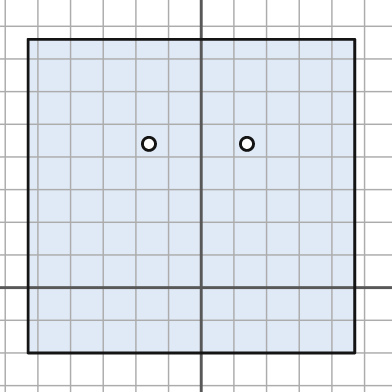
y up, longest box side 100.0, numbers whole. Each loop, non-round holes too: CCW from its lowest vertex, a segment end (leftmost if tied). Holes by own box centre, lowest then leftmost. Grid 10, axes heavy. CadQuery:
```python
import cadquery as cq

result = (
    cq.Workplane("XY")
    .moveTo(-53.0, -20.0)
    .lineTo(47.0, -20.0)
    .lineTo(47.0, 76.0)
    .lineTo(-53.0, 76.0)
    .close()
    .moveTo(-16.0, 44.0)
    .circle(2.0)
    .moveTo(14.0, 44.0)
    .circle(2.0)
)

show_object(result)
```